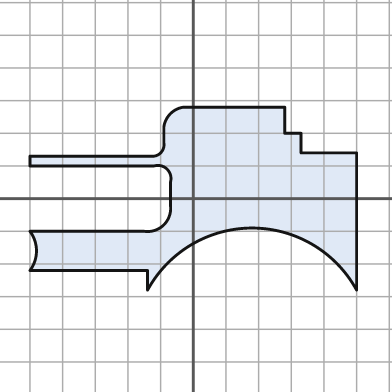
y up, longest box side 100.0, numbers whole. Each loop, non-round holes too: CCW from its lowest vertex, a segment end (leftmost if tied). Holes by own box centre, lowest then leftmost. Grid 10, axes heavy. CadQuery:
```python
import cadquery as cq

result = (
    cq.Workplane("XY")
    .moveTo(-14.0, -28.0)
    .threePointArc((18.0, -9.0), (50.0, -28.0))
    .lineTo(50.0, 14.0)
    .lineTo(33.0, 14.0)
    .lineTo(33.0, 20.0)
    .lineTo(28.0, 20.0)
    .lineTo(28.0, 28.0)
    .lineTo(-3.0, 28.0)
    .threePointArc((-7.0, 26.0), (-9.0, 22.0))
    .lineTo(-9.0, 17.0)
    .threePointArc((-10.0, 14.0), (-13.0, 13.0))
    .lineTo(-50.0, 13.0)
    .lineTo(-50.0, 10.0)
    .lineTo(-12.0, 10.0)
    .threePointArc((-8.0, 9.0), (-7.0, 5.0))
    .lineTo(-7.0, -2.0)
    .threePointArc((-9.0, -8.0), (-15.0, -10.0))
    .lineTo(-50.0, -10.0)
    .threePointArc((-48.0, -16.0), (-50.0, -22.0))
    .lineTo(-14.0, -22.0)
    .close()
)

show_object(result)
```